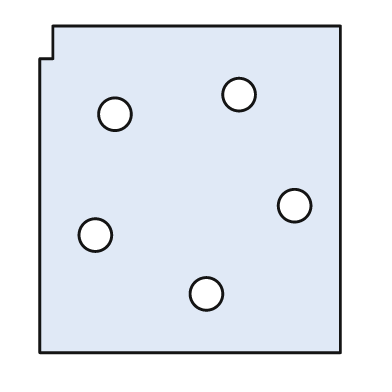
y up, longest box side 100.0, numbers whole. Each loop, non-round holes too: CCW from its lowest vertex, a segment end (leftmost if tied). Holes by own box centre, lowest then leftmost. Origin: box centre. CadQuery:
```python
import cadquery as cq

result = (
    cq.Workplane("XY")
    .moveTo(-46.0, -50.0)
    .lineTo(46.0, -50.0)
    .lineTo(46.0, 50.0)
    .lineTo(-42.0, 50.0)
    .lineTo(-42.0, 40.0)
    .lineTo(-46.0, 40.0)
    .close()
    .moveTo(5.0, -32.0)
    .circle(5.0)
    .moveTo(-29.0, -14.0)
    .circle(5.0)
    .moveTo(32.0, -5.0)
    .circle(5.0)
    .moveTo(-23.0, 23.0)
    .circle(5.0)
    .moveTo(15.0, 29.0)
    .circle(5.0)
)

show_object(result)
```